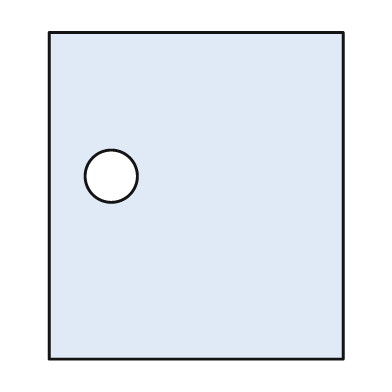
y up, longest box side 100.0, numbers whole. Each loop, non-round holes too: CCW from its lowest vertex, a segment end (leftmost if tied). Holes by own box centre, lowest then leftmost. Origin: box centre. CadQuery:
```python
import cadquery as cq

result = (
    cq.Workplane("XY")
    .moveTo(-45.0, -50.0)
    .lineTo(45.0, -50.0)
    .lineTo(45.0, 50.0)
    .lineTo(-45.0, 50.0)
    .close()
    .moveTo(-26.0, 6.0)
    .circle(8.0)
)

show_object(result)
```